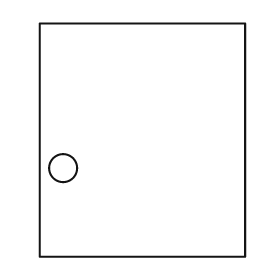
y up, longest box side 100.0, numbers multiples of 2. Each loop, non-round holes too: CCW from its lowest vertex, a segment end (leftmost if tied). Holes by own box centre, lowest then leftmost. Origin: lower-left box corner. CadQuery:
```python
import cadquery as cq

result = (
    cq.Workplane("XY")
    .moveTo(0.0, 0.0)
    .lineTo(88.0, 0.0)
    .lineTo(88.0, 100.0)
    .lineTo(0.0, 100.0)
    .close()
    .moveTo(10.0, 38.0)
    .circle(6.0)
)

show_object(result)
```